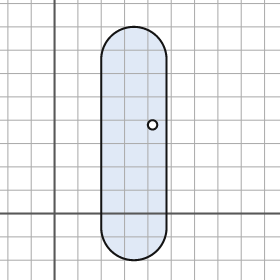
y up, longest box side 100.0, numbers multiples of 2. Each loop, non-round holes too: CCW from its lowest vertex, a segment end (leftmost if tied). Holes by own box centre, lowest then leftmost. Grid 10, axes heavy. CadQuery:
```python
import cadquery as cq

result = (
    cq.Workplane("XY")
    .moveTo(20.0, -6.0)
    .threePointArc((34.0, -20.0), (48.0, -6.0))
    .lineTo(48.0, 66.0)
    .threePointArc((34.0, 80.0), (20.0, 66.0))
    .close()
    .moveTo(42.0, 38.0)
    .circle(2.0)
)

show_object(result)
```